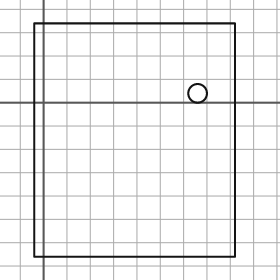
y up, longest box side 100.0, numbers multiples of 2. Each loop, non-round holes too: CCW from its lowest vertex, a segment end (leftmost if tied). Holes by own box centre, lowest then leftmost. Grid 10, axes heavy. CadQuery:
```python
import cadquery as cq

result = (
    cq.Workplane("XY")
    .moveTo(-4.0, -66.0)
    .lineTo(82.0, -66.0)
    .lineTo(82.0, 34.0)
    .lineTo(-4.0, 34.0)
    .close()
    .moveTo(66.0, 4.0)
    .circle(4.0)
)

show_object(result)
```